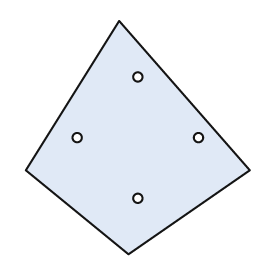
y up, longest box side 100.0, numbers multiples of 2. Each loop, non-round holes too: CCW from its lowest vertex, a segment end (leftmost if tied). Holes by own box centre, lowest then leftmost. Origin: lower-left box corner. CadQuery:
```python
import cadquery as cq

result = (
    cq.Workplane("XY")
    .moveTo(44.0, 0.0)
    .lineTo(96.0, 36.0)
    .lineTo(40.0, 100.0)
    .lineTo(0.0, 36.0)
    .close()
    .moveTo(48.0, 24.0)
    .circle(2.0)
    .moveTo(22.0, 50.0)
    .circle(2.0)
    .moveTo(74.0, 50.0)
    .circle(2.0)
    .moveTo(48.0, 76.0)
    .circle(2.0)
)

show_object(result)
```